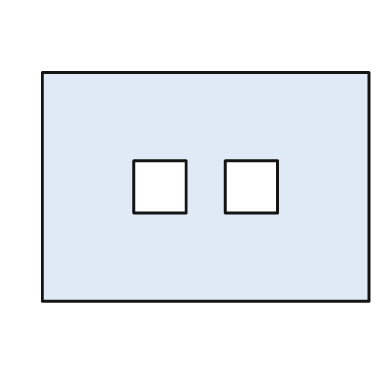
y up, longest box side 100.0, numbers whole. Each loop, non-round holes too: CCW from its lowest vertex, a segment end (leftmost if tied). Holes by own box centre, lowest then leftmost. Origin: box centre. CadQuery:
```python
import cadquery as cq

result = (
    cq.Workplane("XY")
    .moveTo(-50.0, -35.0)
    .lineTo(50.0, -35.0)
    .lineTo(50.0, 35.0)
    .lineTo(-50.0, 35.0)
    .close()
    .moveTo(-22.0, -8.0)
    .lineTo(-6.0, -8.0)
    .lineTo(-6.0, 8.0)
    .lineTo(-22.0, 8.0)
    .close()
    .moveTo(6.0, -8.0)
    .lineTo(22.0, -8.0)
    .lineTo(22.0, 8.0)
    .lineTo(6.0, 8.0)
    .close()
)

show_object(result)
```